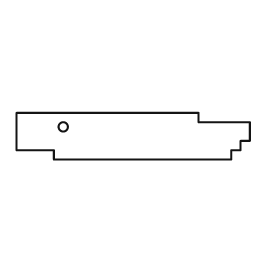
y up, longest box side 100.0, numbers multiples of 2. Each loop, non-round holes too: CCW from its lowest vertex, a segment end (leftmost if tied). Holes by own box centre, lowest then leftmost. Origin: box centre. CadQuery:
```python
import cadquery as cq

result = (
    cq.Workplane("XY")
    .moveTo(-34.0, -10.0)
    .lineTo(42.0, -10.0)
    .lineTo(42.0, -6.0)
    .lineTo(46.0, -6.0)
    .lineTo(46.0, -2.0)
    .lineTo(50.0, -2.0)
    .lineTo(50.0, 6.0)
    .lineTo(28.0, 6.0)
    .lineTo(28.0, 10.0)
    .lineTo(-50.0, 10.0)
    .lineTo(-50.0, -6.0)
    .lineTo(-34.0, -6.0)
    .close()
    .moveTo(-30.0, 4.0)
    .circle(2.0)
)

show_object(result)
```